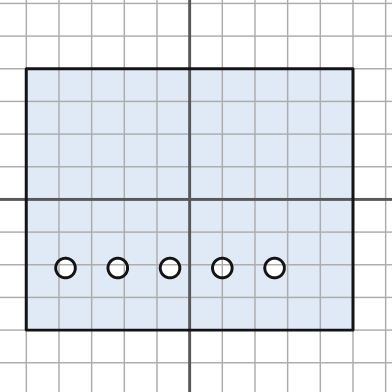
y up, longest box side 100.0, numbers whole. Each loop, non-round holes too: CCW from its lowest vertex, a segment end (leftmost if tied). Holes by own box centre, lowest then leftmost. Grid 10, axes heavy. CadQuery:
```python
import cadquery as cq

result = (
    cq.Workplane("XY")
    .moveTo(-50.0, -40.0)
    .lineTo(50.0, -40.0)
    .lineTo(50.0, 40.0)
    .lineTo(-50.0, 40.0)
    .close()
    .moveTo(-38.0, -21.0)
    .circle(3.0)
    .moveTo(-22.0, -21.0)
    .circle(3.0)
    .moveTo(-6.0, -21.0)
    .circle(3.0)
    .moveTo(10.0, -21.0)
    .circle(3.0)
    .moveTo(26.0, -21.0)
    .circle(3.0)
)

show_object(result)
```